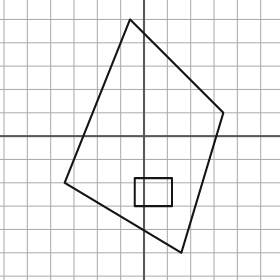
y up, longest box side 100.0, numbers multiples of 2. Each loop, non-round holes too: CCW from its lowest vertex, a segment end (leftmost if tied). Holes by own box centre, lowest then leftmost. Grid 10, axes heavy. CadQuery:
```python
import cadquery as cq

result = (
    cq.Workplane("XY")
    .moveTo(16.0, -50.0)
    .lineTo(34.0, 10.0)
    .lineTo(-6.0, 50.0)
    .lineTo(-34.0, -20.0)
    .close()
    .moveTo(-4.0, -30.0)
    .lineTo(12.0, -30.0)
    .lineTo(12.0, -18.0)
    .lineTo(-4.0, -18.0)
    .close()
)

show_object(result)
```